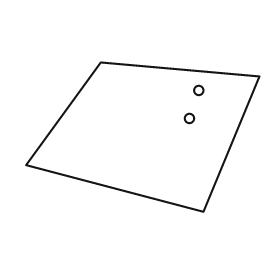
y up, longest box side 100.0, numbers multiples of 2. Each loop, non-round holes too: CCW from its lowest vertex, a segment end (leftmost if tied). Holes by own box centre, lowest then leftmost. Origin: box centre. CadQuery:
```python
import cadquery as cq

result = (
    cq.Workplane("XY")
    .moveTo(26.0, -32.0)
    .lineTo(50.0, 26.0)
    .lineTo(-18.0, 32.0)
    .lineTo(-50.0, -12.0)
    .close()
    .moveTo(20.0, 8.0)
    .circle(2.0)
    .moveTo(24.0, 20.0)
    .circle(2.0)
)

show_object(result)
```